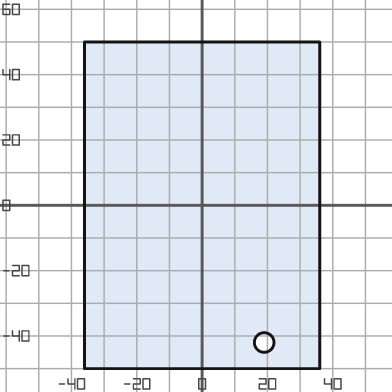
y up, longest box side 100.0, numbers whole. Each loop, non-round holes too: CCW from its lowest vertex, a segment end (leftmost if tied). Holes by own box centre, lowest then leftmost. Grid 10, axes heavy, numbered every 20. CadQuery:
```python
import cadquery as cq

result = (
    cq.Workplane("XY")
    .moveTo(-36.0, -50.0)
    .lineTo(36.0, -50.0)
    .lineTo(36.0, 50.0)
    .lineTo(-36.0, 50.0)
    .close()
    .moveTo(19.0, -42.0)
    .circle(3.0)
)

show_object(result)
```